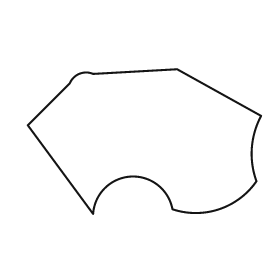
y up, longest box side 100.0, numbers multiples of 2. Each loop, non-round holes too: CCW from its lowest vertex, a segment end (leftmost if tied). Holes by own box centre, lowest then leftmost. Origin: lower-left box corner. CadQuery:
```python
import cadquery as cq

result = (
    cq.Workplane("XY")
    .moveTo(28.0, 0.0)
    .threePointArc((44.0, 16.0), (62.0, 2.0))
    .threePointArc((82.0, 2.0), (98.0, 14.0))
    .threePointArc((96.0, 28.0), (100.0, 42.0))
    .lineTo(64.0, 62.0)
    .lineTo(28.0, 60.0)
    .threePointArc((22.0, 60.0), (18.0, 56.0))
    .lineTo(0.0, 38.0)
    .close()
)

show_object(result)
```